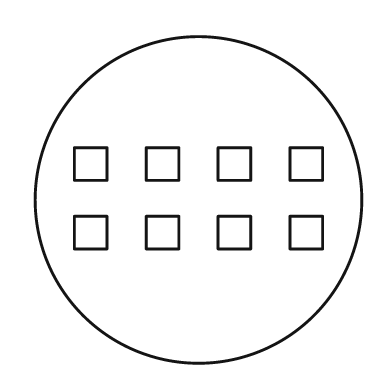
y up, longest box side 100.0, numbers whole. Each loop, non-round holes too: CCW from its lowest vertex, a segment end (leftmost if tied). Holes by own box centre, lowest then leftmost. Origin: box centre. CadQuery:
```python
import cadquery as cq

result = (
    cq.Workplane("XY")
    .moveTo(0.0, 0.0)
    .circle(50.0)
    .moveTo(-38.0, -15.0)
    .lineTo(-28.0, -15.0)
    .lineTo(-28.0, -5.0)
    .lineTo(-38.0, -5.0)
    .close()
    .moveTo(-16.0, -15.0)
    .lineTo(-6.0, -15.0)
    .lineTo(-6.0, -5.0)
    .lineTo(-16.0, -5.0)
    .close()
    .moveTo(6.0, -15.0)
    .lineTo(16.0, -15.0)
    .lineTo(16.0, -5.0)
    .lineTo(6.0, -5.0)
    .close()
    .moveTo(28.0, -15.0)
    .lineTo(38.0, -15.0)
    .lineTo(38.0, -5.0)
    .lineTo(28.0, -5.0)
    .close()
    .moveTo(-38.0, 6.0)
    .lineTo(-28.0, 6.0)
    .lineTo(-28.0, 16.0)
    .lineTo(-38.0, 16.0)
    .close()
    .moveTo(-16.0, 6.0)
    .lineTo(-6.0, 6.0)
    .lineTo(-6.0, 16.0)
    .lineTo(-16.0, 16.0)
    .close()
    .moveTo(6.0, 6.0)
    .lineTo(16.0, 6.0)
    .lineTo(16.0, 16.0)
    .lineTo(6.0, 16.0)
    .close()
    .moveTo(28.0, 6.0)
    .lineTo(38.0, 6.0)
    .lineTo(38.0, 16.0)
    .lineTo(28.0, 16.0)
    .close()
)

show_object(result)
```